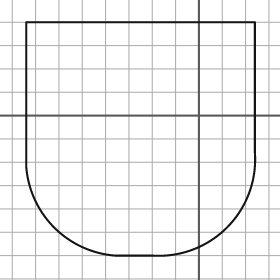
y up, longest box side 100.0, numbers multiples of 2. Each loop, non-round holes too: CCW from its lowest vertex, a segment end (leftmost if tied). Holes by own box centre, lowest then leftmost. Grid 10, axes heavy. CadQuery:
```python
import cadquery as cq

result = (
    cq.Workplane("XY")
    .moveTo(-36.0, -60.0)
    .lineTo(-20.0, -60.0)
    .threePointArc((12.0, -48.0), (24.0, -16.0))
    .lineTo(24.0, 40.0)
    .lineTo(-74.0, 40.0)
    .lineTo(-74.0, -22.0)
    .threePointArc((-62.0, -48.0), (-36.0, -60.0))
    .close()
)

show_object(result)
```